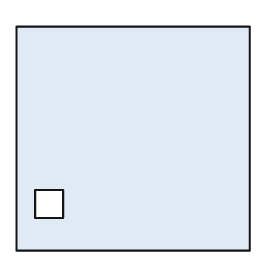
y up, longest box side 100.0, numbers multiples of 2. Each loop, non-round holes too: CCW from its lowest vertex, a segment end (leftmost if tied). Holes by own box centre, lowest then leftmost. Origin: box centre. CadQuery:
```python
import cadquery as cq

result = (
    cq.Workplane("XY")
    .moveTo(-50.0, -48.0)
    .lineTo(50.0, -48.0)
    .lineTo(50.0, 48.0)
    .lineTo(-50.0, 48.0)
    .close()
    .moveTo(-42.0, -34.0)
    .lineTo(-30.0, -34.0)
    .lineTo(-30.0, -22.0)
    .lineTo(-42.0, -22.0)
    .close()
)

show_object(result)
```